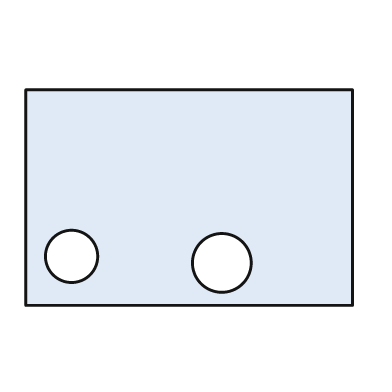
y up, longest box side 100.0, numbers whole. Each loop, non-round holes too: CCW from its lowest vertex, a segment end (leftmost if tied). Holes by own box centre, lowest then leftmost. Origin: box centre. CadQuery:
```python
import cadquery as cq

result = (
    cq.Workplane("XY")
    .moveTo(-50.0, -33.0)
    .lineTo(50.0, -33.0)
    .lineTo(50.0, 33.0)
    .lineTo(-50.0, 33.0)
    .close()
    .moveTo(10.0, -20.0)
    .circle(9.0)
    .moveTo(-36.0, -18.0)
    .circle(8.0)
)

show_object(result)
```